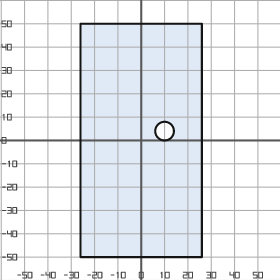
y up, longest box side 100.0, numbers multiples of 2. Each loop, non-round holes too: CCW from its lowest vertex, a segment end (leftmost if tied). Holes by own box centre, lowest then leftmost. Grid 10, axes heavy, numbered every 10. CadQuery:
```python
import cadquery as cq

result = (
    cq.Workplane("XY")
    .moveTo(-26.0, -50.0)
    .lineTo(26.0, -50.0)
    .lineTo(26.0, 50.0)
    .lineTo(-26.0, 50.0)
    .close()
    .moveTo(10.0, 4.0)
    .circle(4.0)
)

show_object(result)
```